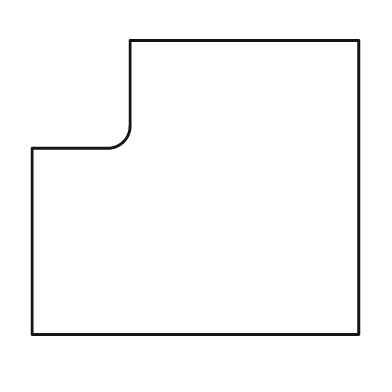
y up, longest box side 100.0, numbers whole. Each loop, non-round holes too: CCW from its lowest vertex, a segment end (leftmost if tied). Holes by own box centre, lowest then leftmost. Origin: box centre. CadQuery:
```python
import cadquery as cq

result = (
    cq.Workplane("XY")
    .moveTo(-50.0, -45.0)
    .lineTo(50.0, -45.0)
    .lineTo(50.0, 45.0)
    .lineTo(-20.0, 45.0)
    .lineTo(-20.0, 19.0)
    .threePointArc((-22.0, 14.0), (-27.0, 12.0))
    .lineTo(-50.0, 12.0)
    .close()
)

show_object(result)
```